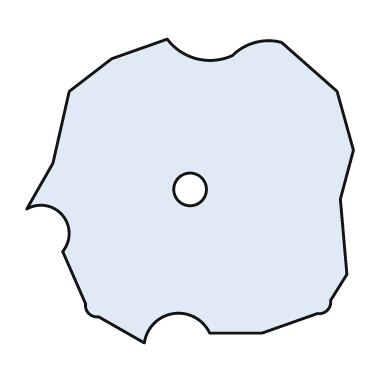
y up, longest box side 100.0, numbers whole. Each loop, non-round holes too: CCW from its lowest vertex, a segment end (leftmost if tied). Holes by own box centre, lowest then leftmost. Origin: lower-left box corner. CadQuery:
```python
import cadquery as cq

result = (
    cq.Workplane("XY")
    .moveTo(36.0, 0.0)
    .threePointArc((45.0, 9.0), (56.0, 3.0))
    .lineTo(72.0, 3.0)
    .lineTo(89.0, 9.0)
    .threePointArc((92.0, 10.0), (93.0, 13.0))
    .lineTo(98.0, 21.0)
    .lineTo(96.0, 44.0)
    .lineTo(100.0, 59.0)
    .lineTo(95.0, 77.0)
    .lineTo(78.0, 92.0)
    .threePointArc((70.0, 92.0), (63.0, 88.0))
    .threePointArc((52.0, 87.0), (43.0, 93.0))
    .lineTo(26.0, 87.0)
    .lineTo(13.0, 77.0)
    .lineTo(8.0, 55.0)
    .lineTo(0.0, 41.0)
    .threePointArc((11.0, 39.0), (11.0, 28.0))
    .lineTo(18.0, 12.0)
    .threePointArc((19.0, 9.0), (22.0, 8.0))
    .close()
    .moveTo(50.0, 47.0)
    .circle(5.0)
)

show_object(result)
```